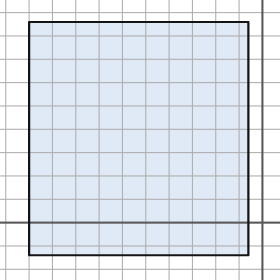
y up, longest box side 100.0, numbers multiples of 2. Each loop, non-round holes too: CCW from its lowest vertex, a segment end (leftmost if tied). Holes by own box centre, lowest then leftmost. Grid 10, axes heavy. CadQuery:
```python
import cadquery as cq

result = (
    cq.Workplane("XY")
    .moveTo(-100.0, -14.0)
    .lineTo(-6.0, -14.0)
    .lineTo(-6.0, 86.0)
    .lineTo(-100.0, 86.0)
    .close()
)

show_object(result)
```